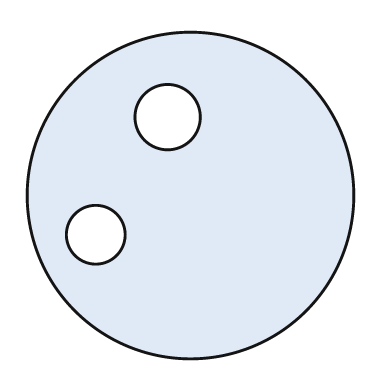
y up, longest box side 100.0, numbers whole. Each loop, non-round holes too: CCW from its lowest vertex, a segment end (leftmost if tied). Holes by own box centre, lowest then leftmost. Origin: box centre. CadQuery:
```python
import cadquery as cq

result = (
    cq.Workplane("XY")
    .moveTo(0.0, 0.0)
    .circle(50.0)
    .moveTo(-29.0, -12.0)
    .circle(9.0)
    .moveTo(-7.0, 24.0)
    .circle(10.0)
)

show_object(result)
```